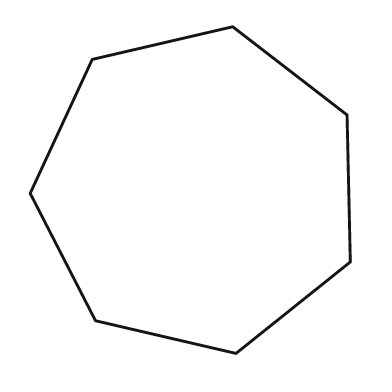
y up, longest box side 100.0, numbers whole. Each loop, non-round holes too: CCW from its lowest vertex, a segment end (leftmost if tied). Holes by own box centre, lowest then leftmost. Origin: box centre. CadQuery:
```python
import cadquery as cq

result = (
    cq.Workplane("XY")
    .moveTo(14.0, -50.0)
    .lineTo(49.0, -22.0)
    .lineTo(48.0, 23.0)
    .lineTo(13.0, 50.0)
    .lineTo(-30.0, 40.0)
    .lineTo(-49.0, -1.0)
    .lineTo(-29.0, -40.0)
    .close()
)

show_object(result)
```